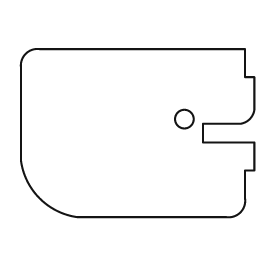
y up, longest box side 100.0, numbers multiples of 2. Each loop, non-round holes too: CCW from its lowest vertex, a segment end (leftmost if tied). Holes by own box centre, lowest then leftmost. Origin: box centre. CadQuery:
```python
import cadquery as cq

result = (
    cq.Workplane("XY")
    .moveTo(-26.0, -36.0)
    .lineTo(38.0, -36.0)
    .threePointArc((44.0, -34.0), (46.0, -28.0))
    .lineTo(46.0, -16.0)
    .lineTo(50.0, -16.0)
    .lineTo(50.0, -4.0)
    .lineTo(28.0, -4.0)
    .lineTo(28.0, 4.0)
    .lineTo(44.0, 4.0)
    .threePointArc((48.0, 6.0), (50.0, 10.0))
    .lineTo(50.0, 24.0)
    .lineTo(46.0, 24.0)
    .lineTo(46.0, 36.0)
    .lineTo(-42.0, 36.0)
    .threePointArc((-48.0, 34.0), (-50.0, 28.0))
    .lineTo(-50.0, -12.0)
    .threePointArc((-42.0, -28.0), (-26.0, -36.0))
    .close()
    .moveTo(20.0, 6.0)
    .circle(4.0)
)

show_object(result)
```